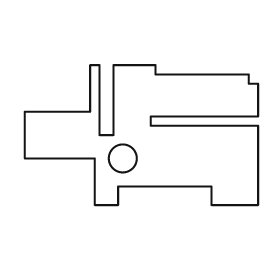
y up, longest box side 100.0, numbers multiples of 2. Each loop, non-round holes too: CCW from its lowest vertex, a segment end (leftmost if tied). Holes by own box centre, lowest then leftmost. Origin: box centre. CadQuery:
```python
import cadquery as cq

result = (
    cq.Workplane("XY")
    .moveTo(-20.0, -30.0)
    .lineTo(-10.0, -30.0)
    .lineTo(-10.0, -22.0)
    .lineTo(30.0, -22.0)
    .lineTo(30.0, -30.0)
    .lineTo(50.0, -30.0)
    .lineTo(50.0, 4.0)
    .lineTo(4.0, 4.0)
    .lineTo(4.0, 8.0)
    .lineTo(50.0, 8.0)
    .lineTo(50.0, 22.0)
    .lineTo(46.0, 22.0)
    .lineTo(46.0, 26.0)
    .lineTo(6.0, 26.0)
    .lineTo(6.0, 30.0)
    .lineTo(-12.0, 30.0)
    .lineTo(-12.0, 0.0)
    .lineTo(-18.0, 0.0)
    .lineTo(-18.0, 30.0)
    .lineTo(-22.0, 30.0)
    .lineTo(-22.0, 10.0)
    .lineTo(-50.0, 10.0)
    .lineTo(-50.0, -10.0)
    .lineTo(-20.0, -10.0)
    .close()
    .moveTo(-8.0, -10.0)
    .circle(6.0)
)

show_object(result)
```